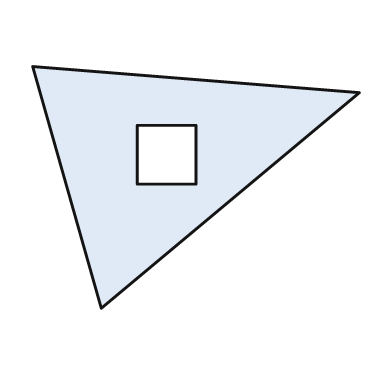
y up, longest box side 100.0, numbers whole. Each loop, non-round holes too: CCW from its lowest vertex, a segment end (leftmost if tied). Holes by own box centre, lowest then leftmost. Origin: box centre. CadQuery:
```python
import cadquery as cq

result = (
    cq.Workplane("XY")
    .moveTo(-29.0, -37.0)
    .lineTo(50.0, 29.0)
    .lineTo(-50.0, 37.0)
    .close()
    .moveTo(-18.0, 1.0)
    .lineTo(0.0, 1.0)
    .lineTo(0.0, 19.0)
    .lineTo(-18.0, 19.0)
    .close()
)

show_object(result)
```